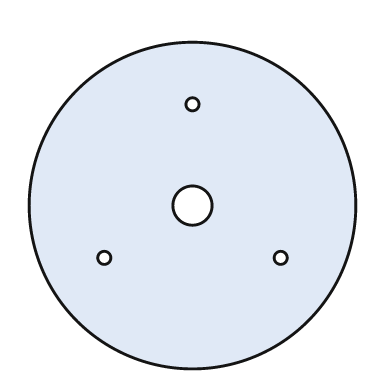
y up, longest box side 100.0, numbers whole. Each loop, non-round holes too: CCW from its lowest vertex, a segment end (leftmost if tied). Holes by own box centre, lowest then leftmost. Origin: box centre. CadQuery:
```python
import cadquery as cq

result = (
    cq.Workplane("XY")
    .moveTo(0.0, 0.0)
    .circle(50.0)
    .moveTo(-27.0, -16.0)
    .circle(2.0)
    .moveTo(27.0, -16.0)
    .circle(2.0)
    .moveTo(0.0, 0.0)
    .circle(6.0)
    .moveTo(0.0, 31.0)
    .circle(2.0)
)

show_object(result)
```